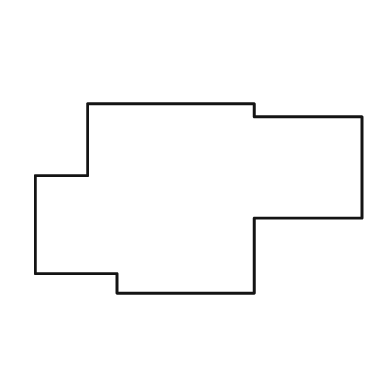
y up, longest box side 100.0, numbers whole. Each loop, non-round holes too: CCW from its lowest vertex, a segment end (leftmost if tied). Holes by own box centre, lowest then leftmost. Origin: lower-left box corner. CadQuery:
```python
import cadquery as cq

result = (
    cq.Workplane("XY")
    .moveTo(25.0, 0.0)
    .lineTo(67.0, 0.0)
    .lineTo(67.0, 23.0)
    .lineTo(100.0, 23.0)
    .lineTo(100.0, 54.0)
    .lineTo(67.0, 54.0)
    .lineTo(67.0, 58.0)
    .lineTo(16.0, 58.0)
    .lineTo(16.0, 36.0)
    .lineTo(0.0, 36.0)
    .lineTo(0.0, 6.0)
    .lineTo(25.0, 6.0)
    .close()
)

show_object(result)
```